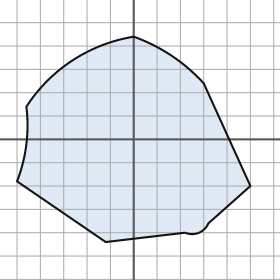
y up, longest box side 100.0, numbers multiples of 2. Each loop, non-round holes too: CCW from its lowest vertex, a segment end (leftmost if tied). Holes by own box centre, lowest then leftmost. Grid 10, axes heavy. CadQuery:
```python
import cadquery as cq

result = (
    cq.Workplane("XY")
    .moveTo(-12.0, -44.0)
    .lineTo(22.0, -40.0)
    .threePointArc((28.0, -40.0), (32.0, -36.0))
    .lineTo(50.0, -20.0)
    .lineTo(30.0, 24.0)
    .threePointArc((16.0, 36.0), (0.0, 44.0))
    .threePointArc((-26.0, 34.0), (-46.0, 14.0))
    .threePointArc((-46.0, -2.0), (-50.0, -18.0))
    .close()
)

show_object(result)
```